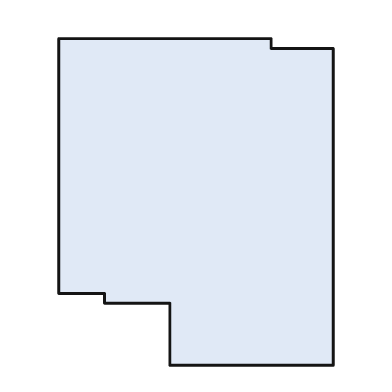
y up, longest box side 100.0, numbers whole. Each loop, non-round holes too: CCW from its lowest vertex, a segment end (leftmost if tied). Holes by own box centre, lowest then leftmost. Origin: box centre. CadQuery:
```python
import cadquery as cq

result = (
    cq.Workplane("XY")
    .moveTo(-8.0, -50.0)
    .lineTo(42.0, -50.0)
    .lineTo(42.0, 47.0)
    .lineTo(23.0, 47.0)
    .lineTo(23.0, 50.0)
    .lineTo(-42.0, 50.0)
    .lineTo(-42.0, -28.0)
    .lineTo(-28.0, -28.0)
    .lineTo(-28.0, -31.0)
    .lineTo(-8.0, -31.0)
    .close()
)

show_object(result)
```